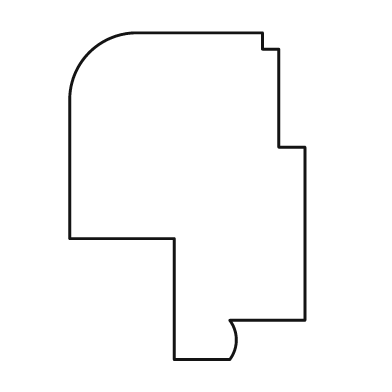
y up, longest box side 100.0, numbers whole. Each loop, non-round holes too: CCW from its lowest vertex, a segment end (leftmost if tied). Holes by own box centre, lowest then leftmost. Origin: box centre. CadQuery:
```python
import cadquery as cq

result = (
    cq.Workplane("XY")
    .moveTo(-4.0, -50.0)
    .lineTo(13.0, -50.0)
    .threePointArc((15.0, -44.0), (13.0, -38.0))
    .lineTo(36.0, -38.0)
    .lineTo(36.0, 15.0)
    .lineTo(28.0, 15.0)
    .lineTo(28.0, 45.0)
    .lineTo(23.0, 45.0)
    .lineTo(23.0, 50.0)
    .lineTo(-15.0, 50.0)
    .threePointArc((-30.0, 44.0), (-36.0, 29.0))
    .lineTo(-36.0, -13.0)
    .lineTo(-4.0, -13.0)
    .close()
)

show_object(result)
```